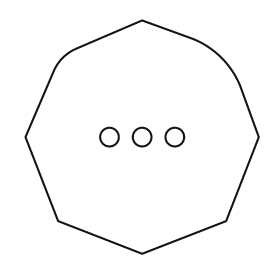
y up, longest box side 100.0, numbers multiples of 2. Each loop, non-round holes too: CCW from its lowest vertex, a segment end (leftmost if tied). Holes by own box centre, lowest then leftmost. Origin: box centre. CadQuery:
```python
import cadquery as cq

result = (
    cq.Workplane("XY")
    .moveTo(0.0, -50.0)
    .lineTo(36.0, -36.0)
    .lineTo(50.0, 0.0)
    .lineTo(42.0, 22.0)
    .threePointArc((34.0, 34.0), (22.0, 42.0))
    .lineTo(0.0, 50.0)
    .lineTo(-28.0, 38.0)
    .threePointArc((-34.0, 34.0), (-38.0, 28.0))
    .lineTo(-50.0, 0.0)
    .lineTo(-36.0, -36.0)
    .close()
    .moveTo(-14.0, 0.0)
    .circle(4.0)
    .moveTo(0.0, 0.0)
    .circle(4.0)
    .moveTo(14.0, 0.0)
    .circle(4.0)
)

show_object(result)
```